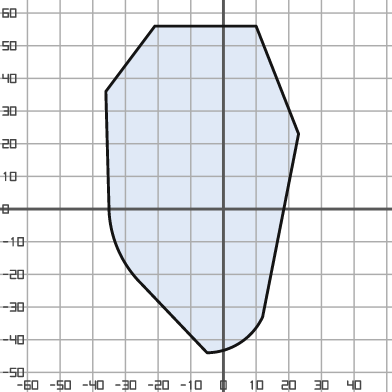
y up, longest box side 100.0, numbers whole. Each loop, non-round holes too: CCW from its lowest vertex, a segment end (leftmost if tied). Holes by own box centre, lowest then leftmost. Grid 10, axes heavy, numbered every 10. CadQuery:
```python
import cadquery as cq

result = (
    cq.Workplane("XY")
    .moveTo(-5.0, -44.0)
    .threePointArc((5.0, -41.0), (12.0, -33.0))
    .lineTo(23.0, 23.0)
    .lineTo(10.0, 56.0)
    .lineTo(-21.0, 56.0)
    .lineTo(-36.0, 36.0)
    .lineTo(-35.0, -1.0)
    .threePointArc((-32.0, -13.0), (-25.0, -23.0))
    .close()
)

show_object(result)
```